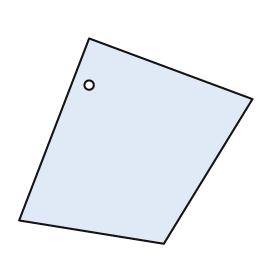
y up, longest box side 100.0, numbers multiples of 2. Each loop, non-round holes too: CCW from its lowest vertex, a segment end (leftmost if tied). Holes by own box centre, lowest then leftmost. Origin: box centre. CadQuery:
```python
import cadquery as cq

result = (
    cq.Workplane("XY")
    .moveTo(12.0, -44.0)
    .lineTo(50.0, 18.0)
    .lineTo(-20.0, 44.0)
    .lineTo(-50.0, -34.0)
    .close()
    .moveTo(-20.0, 24.0)
    .circle(2.0)
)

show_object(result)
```